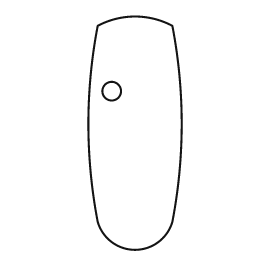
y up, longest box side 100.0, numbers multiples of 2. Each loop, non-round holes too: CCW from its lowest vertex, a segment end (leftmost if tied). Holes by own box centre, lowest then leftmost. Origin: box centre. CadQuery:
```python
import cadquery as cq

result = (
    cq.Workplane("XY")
    .moveTo(-16.0, -38.0)
    .threePointArc((0.0, -50.0), (16.0, -38.0))
    .threePointArc((20.0, 4.0), (16.0, 46.0))
    .threePointArc((0.0, 50.0), (-16.0, 46.0))
    .threePointArc((-20.0, 4.0), (-16.0, -38.0))
    .close()
    .moveTo(-10.0, 18.0)
    .circle(4.0)
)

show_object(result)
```